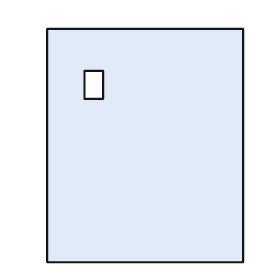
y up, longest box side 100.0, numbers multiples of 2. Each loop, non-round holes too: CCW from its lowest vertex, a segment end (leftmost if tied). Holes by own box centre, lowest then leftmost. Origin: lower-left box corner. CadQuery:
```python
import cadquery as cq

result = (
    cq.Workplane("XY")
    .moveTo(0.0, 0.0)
    .lineTo(84.0, 0.0)
    .lineTo(84.0, 100.0)
    .lineTo(0.0, 100.0)
    .close()
    .moveTo(16.0, 70.0)
    .lineTo(24.0, 70.0)
    .lineTo(24.0, 82.0)
    .lineTo(16.0, 82.0)
    .close()
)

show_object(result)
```